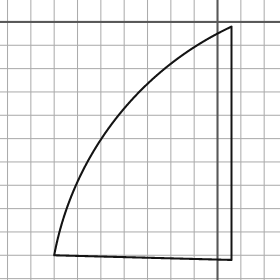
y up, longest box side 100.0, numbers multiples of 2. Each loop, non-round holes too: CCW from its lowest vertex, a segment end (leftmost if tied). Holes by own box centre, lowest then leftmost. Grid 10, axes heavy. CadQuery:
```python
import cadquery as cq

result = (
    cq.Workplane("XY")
    .moveTo(6.0, -102.0)
    .lineTo(6.0, -2.0)
    .threePointArc((-44.0, -42.0), (-70.0, -100.0))
    .close()
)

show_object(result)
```